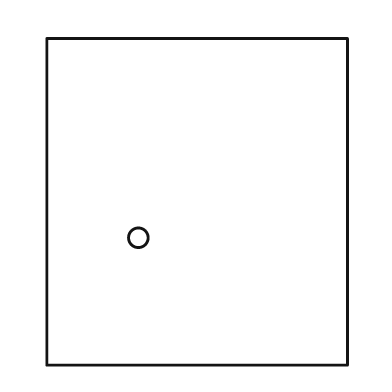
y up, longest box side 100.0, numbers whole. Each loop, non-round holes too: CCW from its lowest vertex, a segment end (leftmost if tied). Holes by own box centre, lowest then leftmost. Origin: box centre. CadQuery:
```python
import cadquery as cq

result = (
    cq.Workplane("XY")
    .moveTo(-46.0, -50.0)
    .lineTo(46.0, -50.0)
    .lineTo(46.0, 50.0)
    .lineTo(-46.0, 50.0)
    .close()
    .moveTo(-18.0, -11.0)
    .circle(3.0)
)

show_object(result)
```